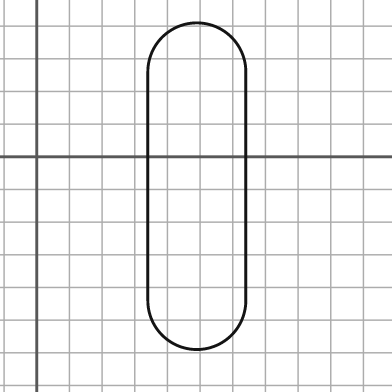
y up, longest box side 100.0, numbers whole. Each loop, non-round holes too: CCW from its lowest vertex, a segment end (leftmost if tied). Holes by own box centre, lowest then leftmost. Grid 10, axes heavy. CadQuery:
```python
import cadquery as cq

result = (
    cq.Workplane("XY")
    .moveTo(34.0, -44.0)
    .threePointArc((49.0, -59.0), (64.0, -44.0))
    .lineTo(64.0, 26.0)
    .threePointArc((49.0, 41.0), (34.0, 26.0))
    .close()
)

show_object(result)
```